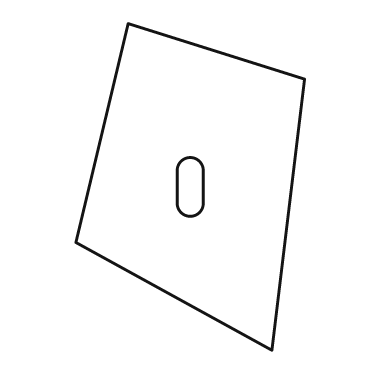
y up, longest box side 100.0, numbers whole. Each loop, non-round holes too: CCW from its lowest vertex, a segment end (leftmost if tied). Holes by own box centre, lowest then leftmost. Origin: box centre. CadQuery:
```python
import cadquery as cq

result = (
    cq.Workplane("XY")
    .moveTo(25.0, -50.0)
    .lineTo(35.0, 33.0)
    .lineTo(-19.0, 50.0)
    .lineTo(-35.0, -17.0)
    .close()
    .moveTo(-4.0, -5.0)
    .threePointArc((0.0, -9.0), (4.0, -5.0))
    .lineTo(4.0, 5.0)
    .threePointArc((0.0, 9.0), (-4.0, 5.0))
    .close()
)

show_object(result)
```